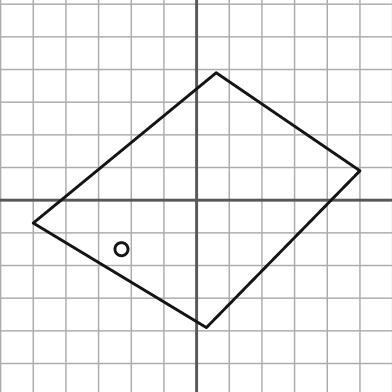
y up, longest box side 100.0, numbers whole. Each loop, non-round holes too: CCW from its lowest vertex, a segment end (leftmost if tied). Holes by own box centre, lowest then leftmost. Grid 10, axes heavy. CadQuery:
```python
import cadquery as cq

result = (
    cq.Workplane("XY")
    .moveTo(3.0, -39.0)
    .lineTo(50.0, 9.0)
    .lineTo(6.0, 39.0)
    .lineTo(-50.0, -7.0)
    .close()
    .moveTo(-23.0, -15.0)
    .circle(2.0)
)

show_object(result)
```